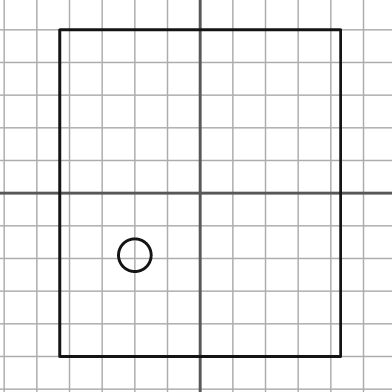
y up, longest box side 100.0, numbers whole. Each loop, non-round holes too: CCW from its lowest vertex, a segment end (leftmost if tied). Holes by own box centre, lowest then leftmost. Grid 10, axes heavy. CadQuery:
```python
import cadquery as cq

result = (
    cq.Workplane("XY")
    .moveTo(-43.0, -50.0)
    .lineTo(43.0, -50.0)
    .lineTo(43.0, 50.0)
    .lineTo(-43.0, 50.0)
    .close()
    .moveTo(-20.0, -19.0)
    .circle(5.0)
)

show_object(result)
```